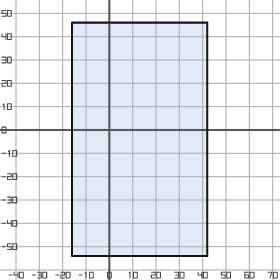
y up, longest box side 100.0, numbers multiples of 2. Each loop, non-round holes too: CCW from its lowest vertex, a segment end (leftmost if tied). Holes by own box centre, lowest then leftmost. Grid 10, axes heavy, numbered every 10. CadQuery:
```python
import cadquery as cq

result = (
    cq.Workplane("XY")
    .moveTo(-16.0, -54.0)
    .lineTo(42.0, -54.0)
    .lineTo(42.0, 46.0)
    .lineTo(-16.0, 46.0)
    .close()
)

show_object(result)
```